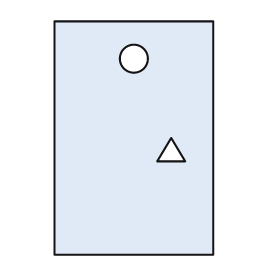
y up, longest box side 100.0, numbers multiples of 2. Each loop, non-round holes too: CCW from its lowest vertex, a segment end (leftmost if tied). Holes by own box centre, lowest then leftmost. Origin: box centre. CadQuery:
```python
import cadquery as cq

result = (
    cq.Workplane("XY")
    .moveTo(-34.0, -50.0)
    .lineTo(34.0, -50.0)
    .lineTo(34.0, 50.0)
    .lineTo(-34.0, 50.0)
    .close()
    .moveTo(10.0, -10.0)
    .lineTo(22.0, -10.0)
    .lineTo(16.0, 0.0)
    .close()
    .moveTo(0.0, 34.0)
    .circle(6.0)
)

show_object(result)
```